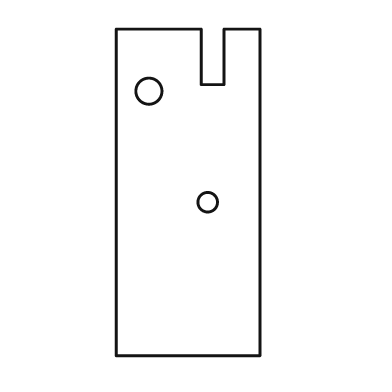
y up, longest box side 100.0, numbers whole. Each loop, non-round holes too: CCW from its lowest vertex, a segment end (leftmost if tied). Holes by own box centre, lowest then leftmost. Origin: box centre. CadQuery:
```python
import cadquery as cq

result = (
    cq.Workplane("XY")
    .moveTo(-22.0, -50.0)
    .lineTo(22.0, -50.0)
    .lineTo(22.0, 50.0)
    .lineTo(11.0, 50.0)
    .lineTo(11.0, 33.0)
    .lineTo(4.0, 33.0)
    .lineTo(4.0, 50.0)
    .lineTo(-22.0, 50.0)
    .close()
    .moveTo(6.0, -3.0)
    .circle(3.0)
    .moveTo(-12.0, 31.0)
    .circle(4.0)
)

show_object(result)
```